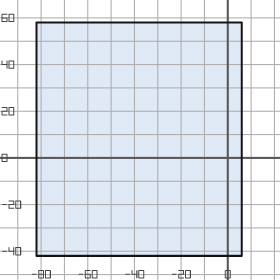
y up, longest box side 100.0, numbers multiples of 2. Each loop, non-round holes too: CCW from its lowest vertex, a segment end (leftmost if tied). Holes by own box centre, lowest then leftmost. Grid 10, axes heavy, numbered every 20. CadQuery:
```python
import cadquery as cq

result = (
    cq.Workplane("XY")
    .moveTo(-82.0, -42.0)
    .lineTo(6.0, -42.0)
    .lineTo(6.0, 58.0)
    .lineTo(-82.0, 58.0)
    .close()
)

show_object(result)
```